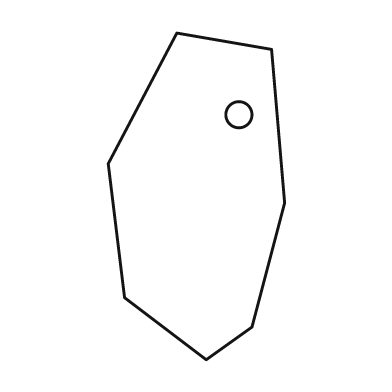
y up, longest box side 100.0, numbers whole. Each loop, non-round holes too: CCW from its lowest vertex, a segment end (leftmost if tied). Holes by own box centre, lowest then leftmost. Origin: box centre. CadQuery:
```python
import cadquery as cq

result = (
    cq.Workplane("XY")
    .moveTo(3.0, -50.0)
    .lineTo(17.0, -40.0)
    .lineTo(27.0, -2.0)
    .lineTo(23.0, 45.0)
    .lineTo(-6.0, 50.0)
    .lineTo(-27.0, 10.0)
    .lineTo(-22.0, -31.0)
    .close()
    .moveTo(13.0, 25.0)
    .circle(4.0)
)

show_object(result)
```